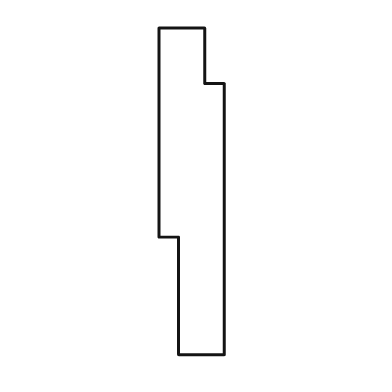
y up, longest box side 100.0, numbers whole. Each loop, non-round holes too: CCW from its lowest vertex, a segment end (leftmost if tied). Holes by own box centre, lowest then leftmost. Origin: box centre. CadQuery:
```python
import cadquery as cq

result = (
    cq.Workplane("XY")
    .moveTo(-4.0, -50.0)
    .lineTo(10.0, -50.0)
    .lineTo(10.0, 33.0)
    .lineTo(4.0, 33.0)
    .lineTo(4.0, 50.0)
    .lineTo(-10.0, 50.0)
    .lineTo(-10.0, -14.0)
    .lineTo(-4.0, -14.0)
    .close()
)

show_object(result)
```